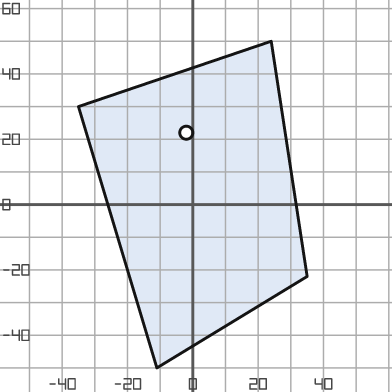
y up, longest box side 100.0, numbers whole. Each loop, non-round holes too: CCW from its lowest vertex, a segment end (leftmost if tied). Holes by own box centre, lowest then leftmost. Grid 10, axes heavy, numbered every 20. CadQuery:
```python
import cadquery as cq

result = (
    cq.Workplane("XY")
    .moveTo(-11.0, -50.0)
    .lineTo(35.0, -22.0)
    .lineTo(24.0, 50.0)
    .lineTo(-35.0, 30.0)
    .close()
    .moveTo(-2.0, 22.0)
    .circle(2.0)
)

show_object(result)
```